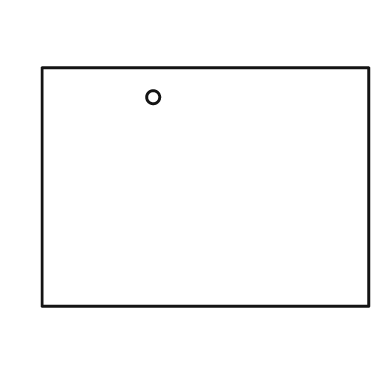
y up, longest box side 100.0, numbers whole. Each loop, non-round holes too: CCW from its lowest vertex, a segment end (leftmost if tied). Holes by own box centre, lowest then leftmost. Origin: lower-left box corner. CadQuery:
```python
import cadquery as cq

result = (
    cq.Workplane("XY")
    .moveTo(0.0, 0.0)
    .lineTo(100.0, 0.0)
    .lineTo(100.0, 73.0)
    .lineTo(0.0, 73.0)
    .close()
    .moveTo(34.0, 64.0)
    .circle(2.0)
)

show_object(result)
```